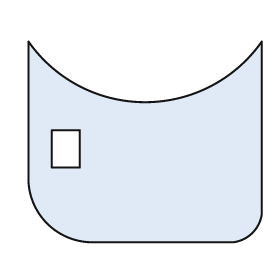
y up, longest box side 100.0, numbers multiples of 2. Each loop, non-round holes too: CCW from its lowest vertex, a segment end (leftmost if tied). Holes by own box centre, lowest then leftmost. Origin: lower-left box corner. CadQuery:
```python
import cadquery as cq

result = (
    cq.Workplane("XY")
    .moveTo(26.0, 0.0)
    .lineTo(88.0, 0.0)
    .threePointArc((96.0, 4.0), (100.0, 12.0))
    .lineTo(100.0, 86.0)
    .threePointArc((50.0, 60.0), (0.0, 86.0))
    .lineTo(0.0, 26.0)
    .threePointArc((8.0, 8.0), (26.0, 0.0))
    .close()
    .moveTo(10.0, 32.0)
    .lineTo(22.0, 32.0)
    .lineTo(22.0, 48.0)
    .lineTo(10.0, 48.0)
    .close()
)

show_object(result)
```